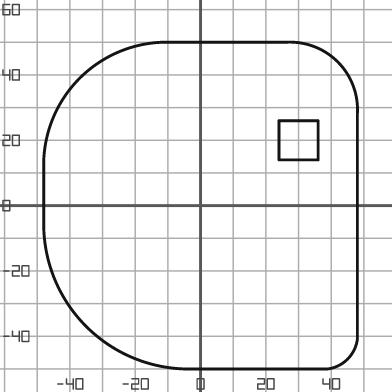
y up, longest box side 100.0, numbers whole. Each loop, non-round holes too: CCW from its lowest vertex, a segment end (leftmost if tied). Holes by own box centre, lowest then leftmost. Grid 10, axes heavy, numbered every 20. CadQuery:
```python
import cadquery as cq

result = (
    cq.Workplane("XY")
    .moveTo(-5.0, -50.0)
    .lineTo(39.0, -50.0)
    .threePointArc((45.0, -47.0), (48.0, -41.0))
    .lineTo(48.0, 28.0)
    .threePointArc((42.0, 44.0), (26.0, 50.0))
    .lineTo(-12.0, 50.0)
    .threePointArc((-37.0, 39.0), (-48.0, 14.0))
    .lineTo(-48.0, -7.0)
    .threePointArc((-35.0, -37.0), (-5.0, -50.0))
    .close()
    .moveTo(24.0, 14.0)
    .lineTo(36.0, 14.0)
    .lineTo(36.0, 26.0)
    .lineTo(24.0, 26.0)
    .close()
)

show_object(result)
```